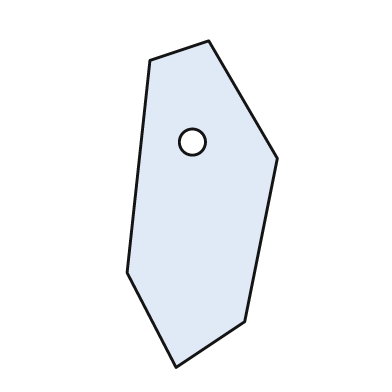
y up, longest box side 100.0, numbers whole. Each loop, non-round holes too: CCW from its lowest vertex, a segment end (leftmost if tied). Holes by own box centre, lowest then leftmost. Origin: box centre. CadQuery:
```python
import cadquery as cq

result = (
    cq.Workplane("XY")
    .moveTo(-8.0, -50.0)
    .lineTo(13.0, -36.0)
    .lineTo(23.0, 14.0)
    .lineTo(2.0, 50.0)
    .lineTo(-16.0, 44.0)
    .lineTo(-23.0, -21.0)
    .close()
    .moveTo(-3.0, 19.0)
    .circle(4.0)
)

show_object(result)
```